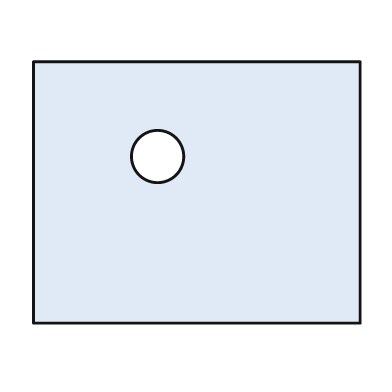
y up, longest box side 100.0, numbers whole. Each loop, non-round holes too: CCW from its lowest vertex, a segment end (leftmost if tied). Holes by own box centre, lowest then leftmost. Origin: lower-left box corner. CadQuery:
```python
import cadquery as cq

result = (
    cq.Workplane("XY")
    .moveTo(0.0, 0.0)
    .lineTo(100.0, 0.0)
    .lineTo(100.0, 80.0)
    .lineTo(0.0, 80.0)
    .close()
    .moveTo(38.0, 51.0)
    .circle(8.0)
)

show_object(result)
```